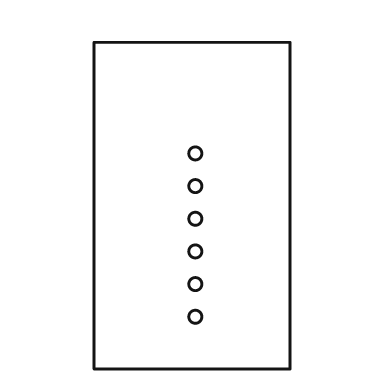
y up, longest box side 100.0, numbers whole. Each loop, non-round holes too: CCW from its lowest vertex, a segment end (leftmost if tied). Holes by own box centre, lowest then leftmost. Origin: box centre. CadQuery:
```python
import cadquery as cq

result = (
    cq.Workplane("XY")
    .moveTo(-30.0, -50.0)
    .lineTo(30.0, -50.0)
    .lineTo(30.0, 50.0)
    .lineTo(-30.0, 50.0)
    .close()
    .moveTo(1.0, -34.0)
    .circle(2.0)
    .moveTo(1.0, -24.0)
    .circle(2.0)
    .moveTo(1.0, -14.0)
    .circle(2.0)
    .moveTo(1.0, -4.0)
    .circle(2.0)
    .moveTo(1.0, 6.0)
    .circle(2.0)
    .moveTo(1.0, 16.0)
    .circle(2.0)
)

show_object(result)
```